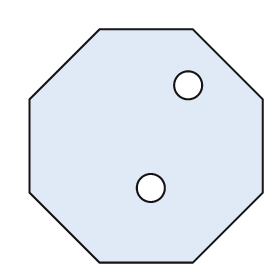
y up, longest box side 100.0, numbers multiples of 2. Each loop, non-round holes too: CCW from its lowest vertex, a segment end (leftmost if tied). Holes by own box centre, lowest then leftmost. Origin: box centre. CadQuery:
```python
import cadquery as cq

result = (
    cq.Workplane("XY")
    .moveTo(-20.0, -50.0)
    .lineTo(20.0, -50.0)
    .lineTo(50.0, -20.0)
    .lineTo(50.0, 20.0)
    .lineTo(20.0, 50.0)
    .lineTo(-20.0, 50.0)
    .lineTo(-50.0, 20.0)
    .lineTo(-50.0, -20.0)
    .close()
    .moveTo(2.0, -18.0)
    .circle(6.0)
    .moveTo(18.0, 26.0)
    .circle(6.0)
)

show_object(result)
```